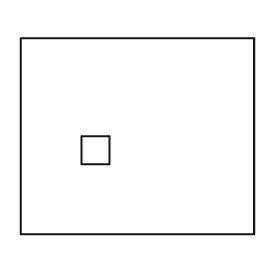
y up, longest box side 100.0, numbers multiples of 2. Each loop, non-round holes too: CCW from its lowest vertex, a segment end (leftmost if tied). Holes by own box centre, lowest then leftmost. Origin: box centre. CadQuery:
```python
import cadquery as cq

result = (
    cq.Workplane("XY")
    .moveTo(-50.0, -42.0)
    .lineTo(50.0, -42.0)
    .lineTo(50.0, 42.0)
    .lineTo(-50.0, 42.0)
    .close()
    .moveTo(-24.0, -12.0)
    .lineTo(-12.0, -12.0)
    .lineTo(-12.0, 0.0)
    .lineTo(-24.0, 0.0)
    .close()
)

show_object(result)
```